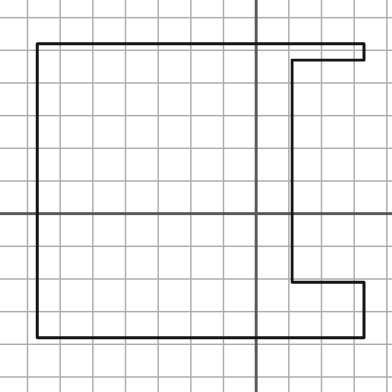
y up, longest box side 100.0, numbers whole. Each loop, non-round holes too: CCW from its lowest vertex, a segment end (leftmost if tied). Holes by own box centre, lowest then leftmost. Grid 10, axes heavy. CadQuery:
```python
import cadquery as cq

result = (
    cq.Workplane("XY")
    .moveTo(-67.0, -38.0)
    .lineTo(33.0, -38.0)
    .lineTo(33.0, -21.0)
    .lineTo(11.0, -21.0)
    .lineTo(11.0, 47.0)
    .lineTo(33.0, 47.0)
    .lineTo(33.0, 52.0)
    .lineTo(-67.0, 52.0)
    .close()
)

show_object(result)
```